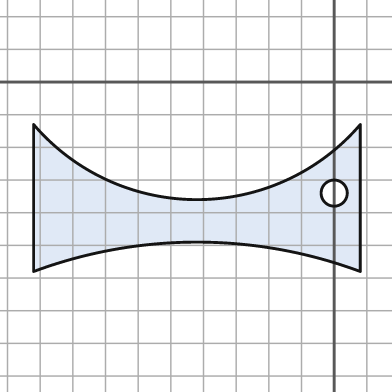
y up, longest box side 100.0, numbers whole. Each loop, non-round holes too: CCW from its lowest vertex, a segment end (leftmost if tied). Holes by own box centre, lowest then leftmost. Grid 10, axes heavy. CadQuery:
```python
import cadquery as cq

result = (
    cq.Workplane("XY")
    .moveTo(-92.0, -58.0)
    .threePointArc((-42.0, -49.0), (8.0, -58.0))
    .lineTo(8.0, -13.0)
    .threePointArc((-42.0, -36.0), (-92.0, -13.0))
    .close()
    .moveTo(0.0, -34.0)
    .circle(4.0)
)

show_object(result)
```